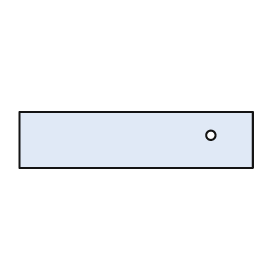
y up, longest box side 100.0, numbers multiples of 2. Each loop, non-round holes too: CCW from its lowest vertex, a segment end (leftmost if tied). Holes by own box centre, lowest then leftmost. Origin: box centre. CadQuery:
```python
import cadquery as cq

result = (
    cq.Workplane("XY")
    .moveTo(-50.0, -12.0)
    .lineTo(50.0, -12.0)
    .lineTo(50.0, 12.0)
    .lineTo(-50.0, 12.0)
    .close()
    .moveTo(32.0, 2.0)
    .circle(2.0)
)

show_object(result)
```